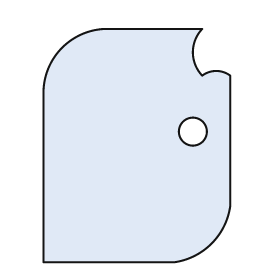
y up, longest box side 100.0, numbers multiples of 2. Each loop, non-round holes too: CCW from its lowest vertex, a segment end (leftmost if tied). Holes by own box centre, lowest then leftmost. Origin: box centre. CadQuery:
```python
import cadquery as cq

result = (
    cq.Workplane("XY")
    .moveTo(-40.0, -50.0)
    .lineTo(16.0, -50.0)
    .threePointArc((32.0, -42.0), (40.0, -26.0))
    .lineTo(40.0, 30.0)
    .threePointArc((34.0, 32.0), (28.0, 30.0))
    .threePointArc((24.0, 40.0), (28.0, 50.0))
    .lineTo(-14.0, 50.0)
    .threePointArc((-32.0, 42.0), (-40.0, 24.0))
    .close()
    .moveTo(24.0, 6.0)
    .circle(6.0)
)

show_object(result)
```